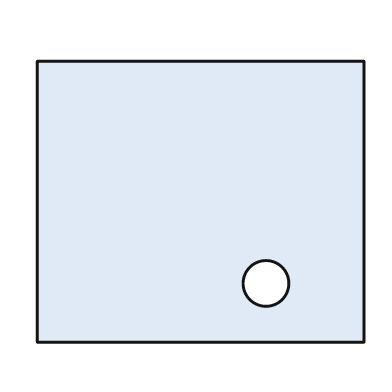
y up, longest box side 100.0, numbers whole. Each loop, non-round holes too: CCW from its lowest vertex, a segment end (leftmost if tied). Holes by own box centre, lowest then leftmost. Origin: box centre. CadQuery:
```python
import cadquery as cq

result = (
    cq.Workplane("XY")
    .moveTo(-50.0, -43.0)
    .lineTo(50.0, -43.0)
    .lineTo(50.0, 43.0)
    .lineTo(-50.0, 43.0)
    .close()
    .moveTo(20.0, -25.0)
    .circle(7.0)
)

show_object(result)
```